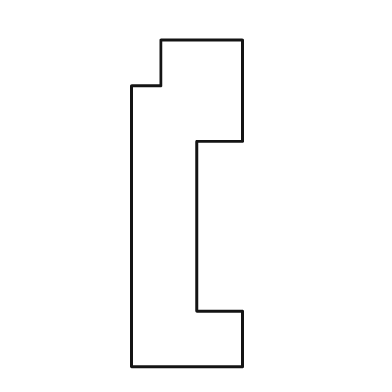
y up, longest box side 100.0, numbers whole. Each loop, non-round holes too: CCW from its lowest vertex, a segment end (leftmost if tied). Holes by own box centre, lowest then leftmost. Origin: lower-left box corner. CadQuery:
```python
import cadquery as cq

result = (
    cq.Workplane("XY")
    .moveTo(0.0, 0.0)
    .lineTo(34.0, 0.0)
    .lineTo(34.0, 17.0)
    .lineTo(20.0, 17.0)
    .lineTo(20.0, 69.0)
    .lineTo(34.0, 69.0)
    .lineTo(34.0, 100.0)
    .lineTo(9.0, 100.0)
    .lineTo(9.0, 86.0)
    .lineTo(0.0, 86.0)
    .close()
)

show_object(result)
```